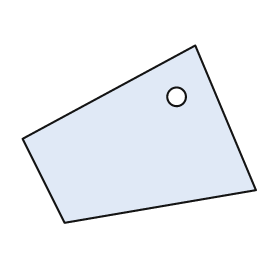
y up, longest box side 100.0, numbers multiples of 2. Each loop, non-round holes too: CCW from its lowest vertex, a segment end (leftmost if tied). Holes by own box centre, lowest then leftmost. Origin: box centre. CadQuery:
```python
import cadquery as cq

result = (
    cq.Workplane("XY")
    .moveTo(-32.0, -38.0)
    .lineTo(50.0, -24.0)
    .lineTo(24.0, 38.0)
    .lineTo(-50.0, -2.0)
    .close()
    .moveTo(16.0, 16.0)
    .circle(4.0)
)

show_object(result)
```